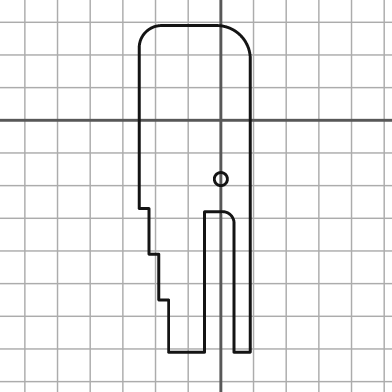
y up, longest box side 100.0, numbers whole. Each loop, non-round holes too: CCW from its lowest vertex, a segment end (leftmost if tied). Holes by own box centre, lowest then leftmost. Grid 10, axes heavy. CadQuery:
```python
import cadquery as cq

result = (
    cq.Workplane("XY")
    .moveTo(-16.0, -71.0)
    .lineTo(-5.0, -71.0)
    .lineTo(-5.0, -28.0)
    .lineTo(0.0, -28.0)
    .threePointArc((3.0, -29.0), (4.0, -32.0))
    .lineTo(4.0, -71.0)
    .lineTo(9.0, -71.0)
    .lineTo(9.0, 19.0)
    .threePointArc((6.0, 26.0), (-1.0, 29.0))
    .lineTo(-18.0, 29.0)
    .threePointArc((-23.0, 27.0), (-25.0, 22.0))
    .lineTo(-25.0, -27.0)
    .lineTo(-22.0, -27.0)
    .lineTo(-22.0, -41.0)
    .lineTo(-19.0, -41.0)
    .lineTo(-19.0, -55.0)
    .lineTo(-16.0, -55.0)
    .close()
    .moveTo(0.0, -18.0)
    .circle(2.0)
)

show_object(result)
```